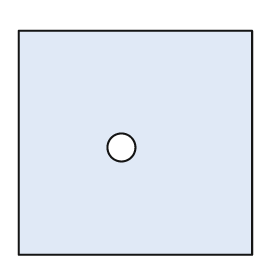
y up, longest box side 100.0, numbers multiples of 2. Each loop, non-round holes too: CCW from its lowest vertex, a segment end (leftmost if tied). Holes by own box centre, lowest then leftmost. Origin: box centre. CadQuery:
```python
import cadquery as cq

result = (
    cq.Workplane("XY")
    .moveTo(-50.0, -48.0)
    .lineTo(50.0, -48.0)
    .lineTo(50.0, 48.0)
    .lineTo(-50.0, 48.0)
    .close()
    .moveTo(-6.0, -2.0)
    .circle(6.0)
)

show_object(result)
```